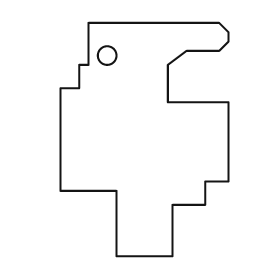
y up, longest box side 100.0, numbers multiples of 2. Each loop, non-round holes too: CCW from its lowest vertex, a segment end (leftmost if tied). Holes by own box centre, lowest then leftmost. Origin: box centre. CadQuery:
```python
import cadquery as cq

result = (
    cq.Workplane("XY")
    .moveTo(-12.0, -50.0)
    .lineTo(12.0, -50.0)
    .lineTo(12.0, -28.0)
    .lineTo(26.0, -28.0)
    .lineTo(26.0, -18.0)
    .lineTo(36.0, -18.0)
    .lineTo(36.0, 16.0)
    .lineTo(10.0, 16.0)
    .lineTo(10.0, 32.0)
    .lineTo(18.0, 38.0)
    .lineTo(32.0, 38.0)
    .lineTo(36.0, 42.0)
    .lineTo(36.0, 46.0)
    .lineTo(32.0, 50.0)
    .lineTo(-24.0, 50.0)
    .lineTo(-24.0, 32.0)
    .lineTo(-28.0, 32.0)
    .lineTo(-28.0, 22.0)
    .lineTo(-36.0, 22.0)
    .lineTo(-36.0, -22.0)
    .lineTo(-12.0, -22.0)
    .close()
    .moveTo(-16.0, 36.0)
    .circle(4.0)
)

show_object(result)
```